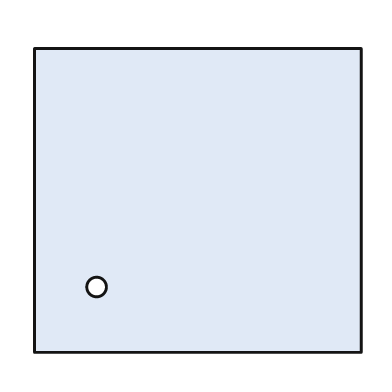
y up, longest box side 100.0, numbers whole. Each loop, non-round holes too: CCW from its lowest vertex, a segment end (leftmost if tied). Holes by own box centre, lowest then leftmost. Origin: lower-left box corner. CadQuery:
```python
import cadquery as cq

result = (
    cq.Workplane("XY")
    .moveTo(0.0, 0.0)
    .lineTo(100.0, 0.0)
    .lineTo(100.0, 93.0)
    .lineTo(0.0, 93.0)
    .close()
    .moveTo(19.0, 20.0)
    .circle(3.0)
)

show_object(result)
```